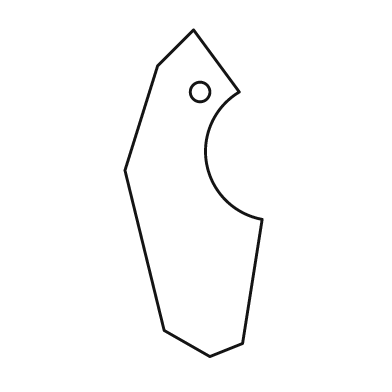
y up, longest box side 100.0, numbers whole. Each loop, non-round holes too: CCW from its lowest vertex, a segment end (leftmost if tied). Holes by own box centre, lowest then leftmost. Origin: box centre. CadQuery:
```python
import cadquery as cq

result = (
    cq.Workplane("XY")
    .moveTo(5.0, -50.0)
    .lineTo(15.0, -46.0)
    .lineTo(21.0, -8.0)
    .threePointArc((4.0, 9.0), (14.0, 31.0))
    .lineTo(0.0, 50.0)
    .lineTo(-11.0, 39.0)
    .lineTo(-21.0, 7.0)
    .lineTo(-9.0, -42.0)
    .close()
    .moveTo(2.0, 31.0)
    .circle(3.0)
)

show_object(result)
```